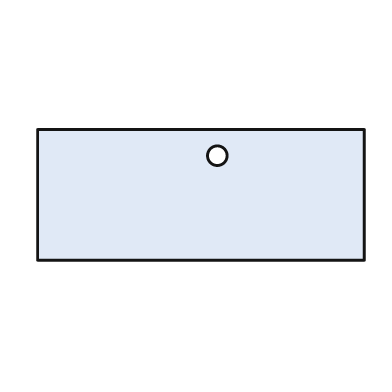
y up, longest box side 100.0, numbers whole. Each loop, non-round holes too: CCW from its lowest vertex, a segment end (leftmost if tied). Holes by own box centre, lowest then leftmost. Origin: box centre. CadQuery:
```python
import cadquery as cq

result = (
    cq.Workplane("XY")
    .moveTo(-50.0, -20.0)
    .lineTo(50.0, -20.0)
    .lineTo(50.0, 20.0)
    .lineTo(-50.0, 20.0)
    .close()
    .moveTo(5.0, 12.0)
    .circle(3.0)
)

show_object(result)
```